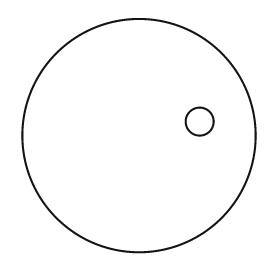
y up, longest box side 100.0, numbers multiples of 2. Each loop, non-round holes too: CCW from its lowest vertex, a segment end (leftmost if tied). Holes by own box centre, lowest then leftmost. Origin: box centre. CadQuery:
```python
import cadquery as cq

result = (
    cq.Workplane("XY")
    .moveTo(0.0, 0.0)
    .circle(50.0)
    .moveTo(26.0, 6.0)
    .circle(6.0)
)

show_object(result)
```